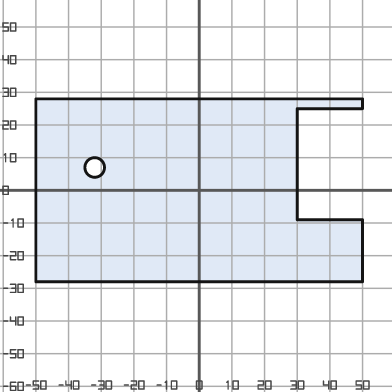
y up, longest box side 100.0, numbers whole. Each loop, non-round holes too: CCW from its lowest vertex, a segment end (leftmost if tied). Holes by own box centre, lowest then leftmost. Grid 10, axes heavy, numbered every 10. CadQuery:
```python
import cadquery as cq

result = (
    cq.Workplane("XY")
    .moveTo(-50.0, -28.0)
    .lineTo(50.0, -28.0)
    .lineTo(50.0, -9.0)
    .lineTo(30.0, -9.0)
    .lineTo(30.0, 25.0)
    .lineTo(50.0, 25.0)
    .lineTo(50.0, 28.0)
    .lineTo(-50.0, 28.0)
    .close()
    .moveTo(-32.0, 7.0)
    .circle(3.0)
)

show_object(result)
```